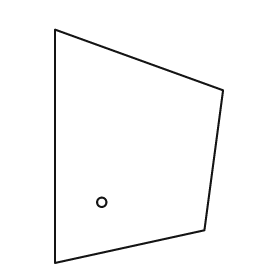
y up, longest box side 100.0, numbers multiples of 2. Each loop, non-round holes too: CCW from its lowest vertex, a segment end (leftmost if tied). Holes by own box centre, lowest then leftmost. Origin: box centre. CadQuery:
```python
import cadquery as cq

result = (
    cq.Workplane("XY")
    .moveTo(-36.0, -50.0)
    .lineTo(28.0, -36.0)
    .lineTo(36.0, 24.0)
    .lineTo(-36.0, 50.0)
    .close()
    .moveTo(-16.0, -24.0)
    .circle(2.0)
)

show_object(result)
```